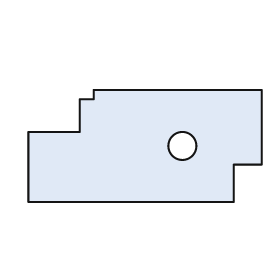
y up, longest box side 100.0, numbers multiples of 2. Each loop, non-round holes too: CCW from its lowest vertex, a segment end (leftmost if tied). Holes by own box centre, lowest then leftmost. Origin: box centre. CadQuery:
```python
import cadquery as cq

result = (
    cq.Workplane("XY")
    .moveTo(-50.0, -24.0)
    .lineTo(38.0, -24.0)
    .lineTo(38.0, -8.0)
    .lineTo(50.0, -8.0)
    .lineTo(50.0, 24.0)
    .lineTo(-22.0, 24.0)
    .lineTo(-22.0, 20.0)
    .lineTo(-28.0, 20.0)
    .lineTo(-28.0, 6.0)
    .lineTo(-50.0, 6.0)
    .close()
    .moveTo(16.0, 0.0)
    .circle(6.0)
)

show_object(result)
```